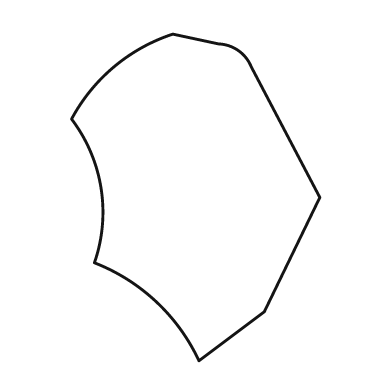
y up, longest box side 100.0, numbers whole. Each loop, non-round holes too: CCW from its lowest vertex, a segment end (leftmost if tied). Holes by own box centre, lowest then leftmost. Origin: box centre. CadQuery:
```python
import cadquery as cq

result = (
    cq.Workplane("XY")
    .moveTo(1.0, -50.0)
    .lineTo(21.0, -35.0)
    .lineTo(38.0, 0.0)
    .lineTo(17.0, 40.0)
    .threePointArc((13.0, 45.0), (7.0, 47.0))
    .lineTo(-7.0, 50.0)
    .threePointArc((-25.0, 40.0), (-38.0, 24.0))
    .threePointArc((-29.0, 3.0), (-31.0, -20.0))
    .threePointArc((-12.0, -32.0), (1.0, -50.0))
    .close()
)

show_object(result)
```